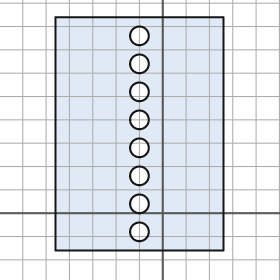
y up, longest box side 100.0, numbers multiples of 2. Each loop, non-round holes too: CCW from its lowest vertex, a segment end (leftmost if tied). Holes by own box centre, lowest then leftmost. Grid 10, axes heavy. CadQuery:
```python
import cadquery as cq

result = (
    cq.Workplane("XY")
    .moveTo(-46.0, -16.0)
    .lineTo(26.0, -16.0)
    .lineTo(26.0, 84.0)
    .lineTo(-46.0, 84.0)
    .close()
    .moveTo(-10.0, -8.0)
    .circle(4.0)
    .moveTo(-10.0, 4.0)
    .circle(4.0)
    .moveTo(-10.0, 16.0)
    .circle(4.0)
    .moveTo(-10.0, 28.0)
    .circle(4.0)
    .moveTo(-10.0, 40.0)
    .circle(4.0)
    .moveTo(-10.0, 52.0)
    .circle(4.0)
    .moveTo(-10.0, 64.0)
    .circle(4.0)
    .moveTo(-10.0, 76.0)
    .circle(4.0)
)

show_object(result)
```